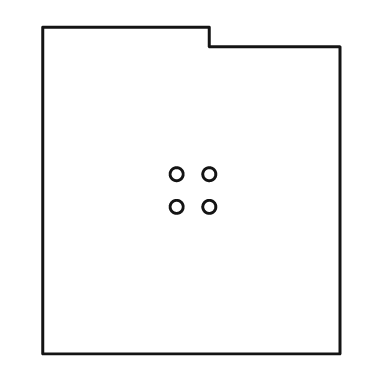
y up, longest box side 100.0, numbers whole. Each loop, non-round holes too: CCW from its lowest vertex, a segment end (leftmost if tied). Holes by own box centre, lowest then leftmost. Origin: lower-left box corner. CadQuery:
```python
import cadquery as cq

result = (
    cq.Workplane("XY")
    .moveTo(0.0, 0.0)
    .lineTo(91.0, 0.0)
    .lineTo(91.0, 94.0)
    .lineTo(51.0, 94.0)
    .lineTo(51.0, 100.0)
    .lineTo(0.0, 100.0)
    .close()
    .moveTo(41.0, 45.0)
    .circle(2.0)
    .moveTo(51.0, 45.0)
    .circle(2.0)
    .moveTo(41.0, 55.0)
    .circle(2.0)
    .moveTo(51.0, 55.0)
    .circle(2.0)
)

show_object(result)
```